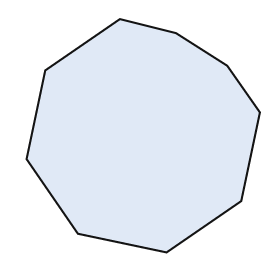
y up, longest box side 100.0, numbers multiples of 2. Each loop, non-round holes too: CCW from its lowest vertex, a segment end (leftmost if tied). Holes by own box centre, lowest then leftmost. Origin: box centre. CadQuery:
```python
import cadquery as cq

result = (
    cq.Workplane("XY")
    .moveTo(10.0, -50.0)
    .lineTo(42.0, -28.0)
    .lineTo(50.0, 10.0)
    .lineTo(36.0, 30.0)
    .lineTo(14.0, 44.0)
    .lineTo(-10.0, 50.0)
    .lineTo(-42.0, 28.0)
    .lineTo(-50.0, -10.0)
    .lineTo(-28.0, -42.0)
    .close()
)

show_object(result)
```